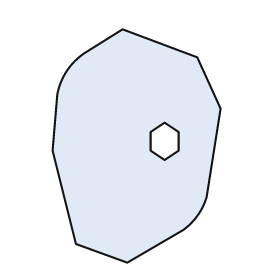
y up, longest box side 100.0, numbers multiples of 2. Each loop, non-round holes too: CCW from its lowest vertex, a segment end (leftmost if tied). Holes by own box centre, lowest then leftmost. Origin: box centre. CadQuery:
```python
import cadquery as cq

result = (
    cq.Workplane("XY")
    .moveTo(-4.0, -50.0)
    .lineTo(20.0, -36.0)
    .threePointArc((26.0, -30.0), (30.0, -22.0))
    .lineTo(36.0, 16.0)
    .lineTo(26.0, 38.0)
    .lineTo(-6.0, 50.0)
    .lineTo(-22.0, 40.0)
    .threePointArc((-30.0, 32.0), (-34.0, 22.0))
    .lineTo(-36.0, -2.0)
    .lineTo(-26.0, -42.0)
    .close()
    .moveTo(12.0, -6.0)
    .lineTo(18.0, -2.0)
    .lineTo(18.0, 6.0)
    .lineTo(12.0, 10.0)
    .lineTo(6.0, 6.0)
    .lineTo(6.0, -2.0)
    .close()
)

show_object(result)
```